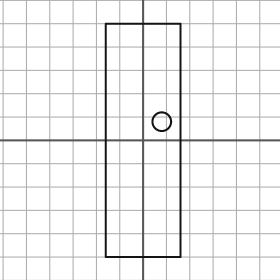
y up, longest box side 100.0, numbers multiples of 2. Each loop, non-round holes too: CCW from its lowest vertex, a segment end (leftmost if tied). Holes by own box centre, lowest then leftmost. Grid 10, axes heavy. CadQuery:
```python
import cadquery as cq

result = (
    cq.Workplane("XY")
    .moveTo(-16.0, -50.0)
    .lineTo(16.0, -50.0)
    .lineTo(16.0, 50.0)
    .lineTo(-16.0, 50.0)
    .close()
    .moveTo(8.0, 8.0)
    .circle(4.0)
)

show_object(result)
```